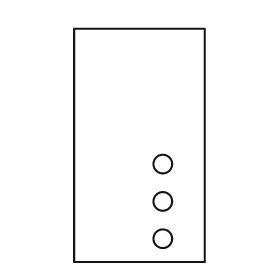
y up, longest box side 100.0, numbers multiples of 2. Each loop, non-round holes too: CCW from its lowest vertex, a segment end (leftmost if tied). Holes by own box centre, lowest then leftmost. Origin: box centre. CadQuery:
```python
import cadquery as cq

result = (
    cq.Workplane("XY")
    .moveTo(-28.0, -50.0)
    .lineTo(28.0, -50.0)
    .lineTo(28.0, 50.0)
    .lineTo(-28.0, 50.0)
    .close()
    .moveTo(10.0, -40.0)
    .circle(4.0)
    .moveTo(10.0, -24.0)
    .circle(4.0)
    .moveTo(10.0, -8.0)
    .circle(4.0)
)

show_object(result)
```